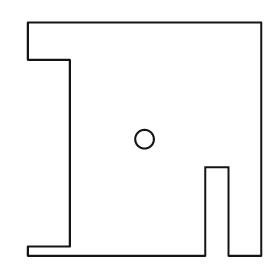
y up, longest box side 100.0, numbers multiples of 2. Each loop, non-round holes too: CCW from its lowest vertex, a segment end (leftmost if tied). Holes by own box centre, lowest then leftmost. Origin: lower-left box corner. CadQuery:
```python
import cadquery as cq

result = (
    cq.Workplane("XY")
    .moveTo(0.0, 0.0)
    .lineTo(76.0, 0.0)
    .lineTo(76.0, 38.0)
    .lineTo(86.0, 38.0)
    .lineTo(86.0, 0.0)
    .lineTo(100.0, 0.0)
    .lineTo(100.0, 100.0)
    .lineTo(0.0, 100.0)
    .lineTo(0.0, 84.0)
    .lineTo(18.0, 84.0)
    .lineTo(18.0, 4.0)
    .lineTo(0.0, 4.0)
    .close()
    .moveTo(50.0, 50.0)
    .circle(4.0)
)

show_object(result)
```